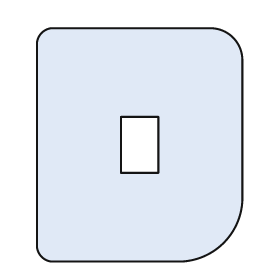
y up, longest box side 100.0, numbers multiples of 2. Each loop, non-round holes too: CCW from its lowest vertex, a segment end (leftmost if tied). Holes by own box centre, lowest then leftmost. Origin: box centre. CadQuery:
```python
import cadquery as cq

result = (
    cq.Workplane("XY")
    .moveTo(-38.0, -50.0)
    .lineTo(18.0, -50.0)
    .threePointArc((36.0, -42.0), (44.0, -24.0))
    .lineTo(44.0, 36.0)
    .threePointArc((40.0, 46.0), (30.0, 50.0))
    .lineTo(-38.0, 50.0)
    .threePointArc((-42.0, 48.0), (-44.0, 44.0))
    .lineTo(-44.0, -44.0)
    .threePointArc((-42.0, -48.0), (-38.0, -50.0))
    .close()
    .moveTo(-8.0, -12.0)
    .lineTo(8.0, -12.0)
    .lineTo(8.0, 12.0)
    .lineTo(-8.0, 12.0)
    .close()
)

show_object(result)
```